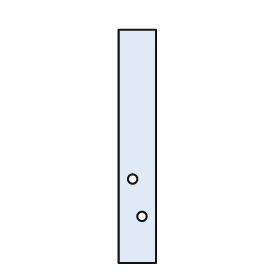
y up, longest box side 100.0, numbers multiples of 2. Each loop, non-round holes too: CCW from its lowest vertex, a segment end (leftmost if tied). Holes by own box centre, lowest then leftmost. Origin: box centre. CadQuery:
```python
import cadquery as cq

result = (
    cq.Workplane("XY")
    .moveTo(-8.0, -50.0)
    .lineTo(8.0, -50.0)
    .lineTo(8.0, 50.0)
    .lineTo(-8.0, 50.0)
    .close()
    .moveTo(2.0, -30.0)
    .circle(2.0)
    .moveTo(-2.0, -14.0)
    .circle(2.0)
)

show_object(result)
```